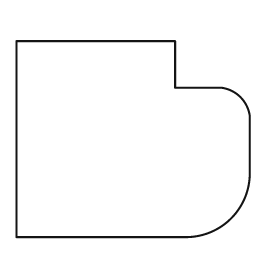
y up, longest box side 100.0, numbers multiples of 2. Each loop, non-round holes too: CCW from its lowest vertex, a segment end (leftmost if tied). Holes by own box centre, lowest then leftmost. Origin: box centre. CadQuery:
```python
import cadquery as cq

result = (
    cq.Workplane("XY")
    .moveTo(-50.0, -42.0)
    .lineTo(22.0, -42.0)
    .threePointArc((42.0, -34.0), (50.0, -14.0))
    .lineTo(50.0, 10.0)
    .threePointArc((46.0, 18.0), (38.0, 22.0))
    .lineTo(18.0, 22.0)
    .lineTo(18.0, 42.0)
    .lineTo(-50.0, 42.0)
    .close()
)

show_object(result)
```